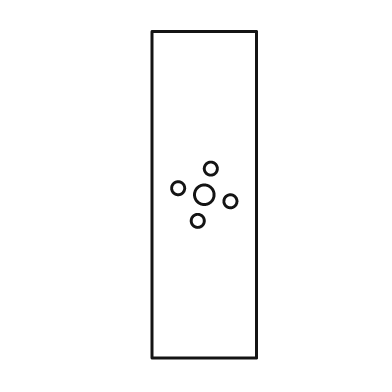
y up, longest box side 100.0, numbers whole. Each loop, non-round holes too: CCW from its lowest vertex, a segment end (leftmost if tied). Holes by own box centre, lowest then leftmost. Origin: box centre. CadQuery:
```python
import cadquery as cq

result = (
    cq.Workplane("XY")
    .moveTo(-16.0, -50.0)
    .lineTo(16.0, -50.0)
    .lineTo(16.0, 50.0)
    .lineTo(-16.0, 50.0)
    .close()
    .moveTo(-2.0, -8.0)
    .circle(2.0)
    .moveTo(8.0, -2.0)
    .circle(2.0)
    .moveTo(0.0, 0.0)
    .circle(3.0)
    .moveTo(-8.0, 2.0)
    .circle(2.0)
    .moveTo(2.0, 8.0)
    .circle(2.0)
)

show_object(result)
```